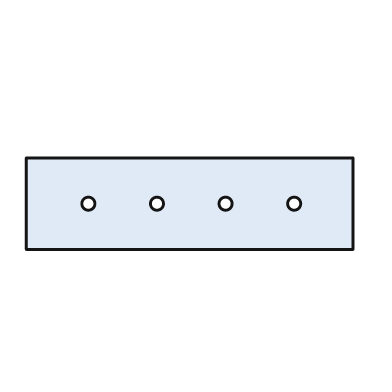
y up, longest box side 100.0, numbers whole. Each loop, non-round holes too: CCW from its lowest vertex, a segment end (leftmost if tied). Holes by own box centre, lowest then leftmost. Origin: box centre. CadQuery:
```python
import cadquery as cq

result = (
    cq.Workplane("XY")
    .moveTo(-50.0, -14.0)
    .lineTo(50.0, -14.0)
    .lineTo(50.0, 14.0)
    .lineTo(-50.0, 14.0)
    .close()
    .moveTo(-31.0, 0.0)
    .circle(2.0)
    .moveTo(-10.0, 0.0)
    .circle(2.0)
    .moveTo(11.0, 0.0)
    .circle(2.0)
    .moveTo(32.0, 0.0)
    .circle(2.0)
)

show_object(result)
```